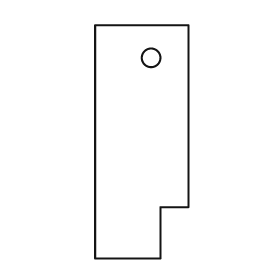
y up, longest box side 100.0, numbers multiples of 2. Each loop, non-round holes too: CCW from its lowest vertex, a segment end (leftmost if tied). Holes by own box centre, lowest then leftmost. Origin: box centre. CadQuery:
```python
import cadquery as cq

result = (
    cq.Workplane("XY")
    .moveTo(-20.0, -50.0)
    .lineTo(8.0, -50.0)
    .lineTo(8.0, -28.0)
    .lineTo(20.0, -28.0)
    .lineTo(20.0, 50.0)
    .lineTo(-20.0, 50.0)
    .close()
    .moveTo(4.0, 36.0)
    .circle(4.0)
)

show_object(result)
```